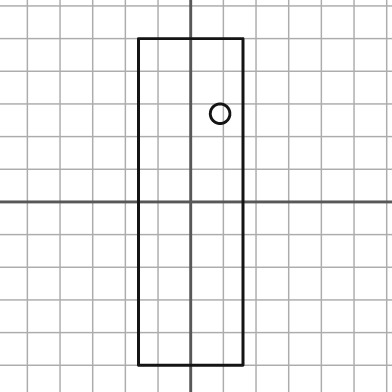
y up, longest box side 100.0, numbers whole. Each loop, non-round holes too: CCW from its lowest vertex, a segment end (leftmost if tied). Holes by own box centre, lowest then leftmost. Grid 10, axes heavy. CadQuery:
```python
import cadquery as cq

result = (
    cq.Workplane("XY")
    .moveTo(-16.0, -50.0)
    .lineTo(16.0, -50.0)
    .lineTo(16.0, 50.0)
    .lineTo(-16.0, 50.0)
    .close()
    .moveTo(9.0, 27.0)
    .circle(3.0)
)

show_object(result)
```